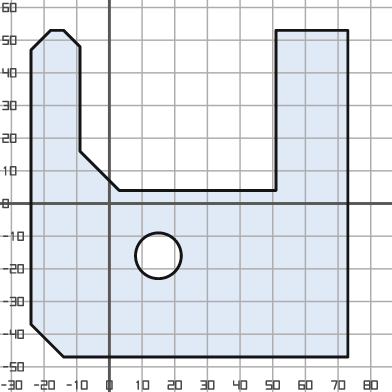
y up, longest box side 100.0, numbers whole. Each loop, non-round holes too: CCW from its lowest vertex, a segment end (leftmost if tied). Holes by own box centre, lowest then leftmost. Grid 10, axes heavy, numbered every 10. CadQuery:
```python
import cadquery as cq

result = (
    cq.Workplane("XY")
    .moveTo(-14.0, -47.0)
    .lineTo(73.0, -47.0)
    .lineTo(73.0, 53.0)
    .lineTo(51.0, 53.0)
    .lineTo(51.0, 4.0)
    .lineTo(3.0, 4.0)
    .lineTo(-9.0, 16.0)
    .lineTo(-9.0, 48.0)
    .lineTo(-14.0, 53.0)
    .lineTo(-18.0, 53.0)
    .lineTo(-24.0, 47.0)
    .lineTo(-24.0, -37.0)
    .close()
    .moveTo(15.0, -16.0)
    .circle(7.0)
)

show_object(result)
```